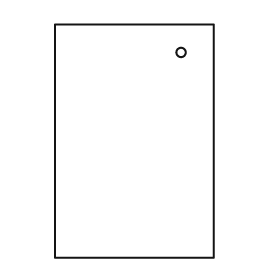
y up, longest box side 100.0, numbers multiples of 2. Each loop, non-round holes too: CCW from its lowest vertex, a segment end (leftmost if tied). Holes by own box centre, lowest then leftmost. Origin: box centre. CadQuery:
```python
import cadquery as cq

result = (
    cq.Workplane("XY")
    .moveTo(-34.0, -50.0)
    .lineTo(34.0, -50.0)
    .lineTo(34.0, 50.0)
    .lineTo(-34.0, 50.0)
    .close()
    .moveTo(20.0, 38.0)
    .circle(2.0)
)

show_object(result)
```